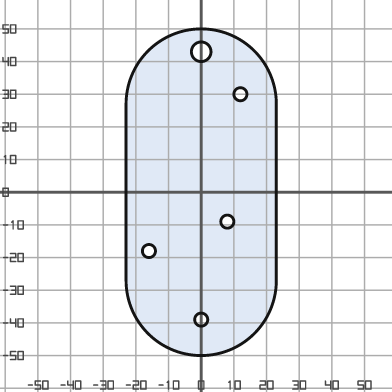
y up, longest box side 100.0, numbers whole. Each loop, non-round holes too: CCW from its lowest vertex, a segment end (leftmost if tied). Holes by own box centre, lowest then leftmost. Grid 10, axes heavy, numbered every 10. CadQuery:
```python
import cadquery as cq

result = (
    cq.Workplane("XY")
    .moveTo(-23.0, -27.0)
    .threePointArc((0.0, -50.0), (23.0, -27.0))
    .lineTo(23.0, 27.0)
    .threePointArc((0.0, 50.0), (-23.0, 27.0))
    .close()
    .moveTo(0.0, -39.0)
    .circle(2.0)
    .moveTo(-16.0, -18.0)
    .circle(2.0)
    .moveTo(8.0, -9.0)
    .circle(2.0)
    .moveTo(12.0, 30.0)
    .circle(2.0)
    .moveTo(0.0, 43.0)
    .circle(3.0)
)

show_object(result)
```